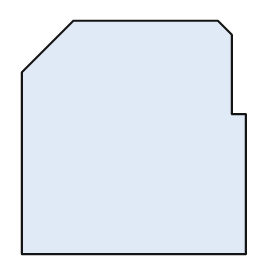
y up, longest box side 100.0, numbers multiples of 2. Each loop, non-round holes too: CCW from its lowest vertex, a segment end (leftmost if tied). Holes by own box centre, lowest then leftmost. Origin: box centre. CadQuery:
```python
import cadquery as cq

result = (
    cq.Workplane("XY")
    .moveTo(-48.0, -50.0)
    .lineTo(48.0, -50.0)
    .lineTo(48.0, 10.0)
    .lineTo(42.0, 10.0)
    .lineTo(42.0, 44.0)
    .lineTo(36.0, 50.0)
    .lineTo(-26.0, 50.0)
    .lineTo(-48.0, 28.0)
    .close()
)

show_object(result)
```